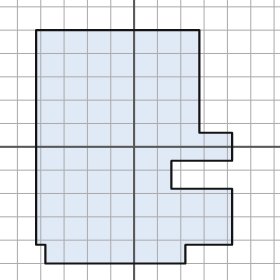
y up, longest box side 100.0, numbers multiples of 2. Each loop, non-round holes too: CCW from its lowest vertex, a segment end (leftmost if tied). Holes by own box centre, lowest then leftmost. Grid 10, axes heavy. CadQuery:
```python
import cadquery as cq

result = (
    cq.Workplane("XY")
    .moveTo(-38.0, -50.0)
    .lineTo(22.0, -50.0)
    .lineTo(22.0, -42.0)
    .lineTo(42.0, -42.0)
    .lineTo(42.0, -18.0)
    .lineTo(16.0, -18.0)
    .lineTo(16.0, -6.0)
    .lineTo(42.0, -6.0)
    .lineTo(42.0, 6.0)
    .lineTo(28.0, 6.0)
    .lineTo(28.0, 50.0)
    .lineTo(-42.0, 50.0)
    .lineTo(-42.0, -42.0)
    .lineTo(-38.0, -42.0)
    .close()
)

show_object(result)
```